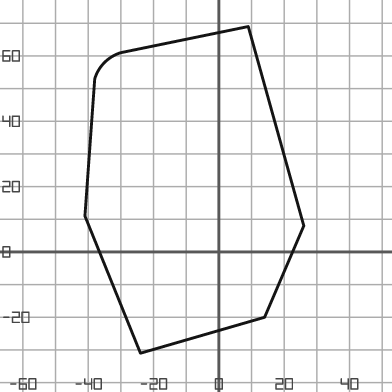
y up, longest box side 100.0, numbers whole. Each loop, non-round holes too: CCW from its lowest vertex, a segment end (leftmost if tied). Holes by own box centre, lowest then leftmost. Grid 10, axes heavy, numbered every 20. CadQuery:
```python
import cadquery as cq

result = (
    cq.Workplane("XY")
    .moveTo(-24.0, -31.0)
    .lineTo(14.0, -20.0)
    .lineTo(26.0, 8.0)
    .lineTo(9.0, 69.0)
    .lineTo(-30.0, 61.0)
    .threePointArc((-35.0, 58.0), (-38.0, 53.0))
    .lineTo(-41.0, 11.0)
    .close()
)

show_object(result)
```